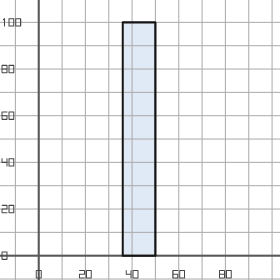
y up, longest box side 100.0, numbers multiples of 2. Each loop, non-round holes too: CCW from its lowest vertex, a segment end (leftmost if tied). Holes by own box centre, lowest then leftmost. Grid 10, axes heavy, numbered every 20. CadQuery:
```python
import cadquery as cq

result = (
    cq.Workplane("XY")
    .moveTo(36.0, 0.0)
    .lineTo(50.0, 0.0)
    .lineTo(50.0, 100.0)
    .lineTo(36.0, 100.0)
    .close()
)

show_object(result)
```